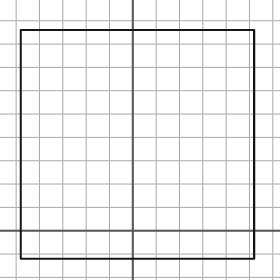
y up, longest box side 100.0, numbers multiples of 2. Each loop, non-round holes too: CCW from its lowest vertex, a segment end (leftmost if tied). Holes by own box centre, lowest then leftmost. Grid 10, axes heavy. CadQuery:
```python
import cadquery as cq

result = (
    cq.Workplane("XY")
    .moveTo(-48.0, -12.0)
    .lineTo(52.0, -12.0)
    .lineTo(52.0, 86.0)
    .lineTo(-48.0, 86.0)
    .close()
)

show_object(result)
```